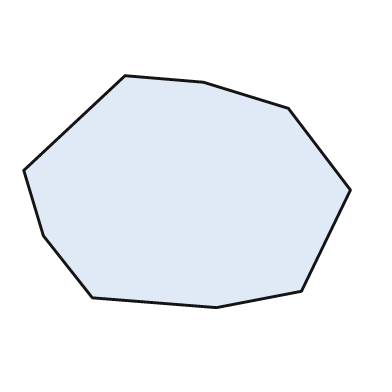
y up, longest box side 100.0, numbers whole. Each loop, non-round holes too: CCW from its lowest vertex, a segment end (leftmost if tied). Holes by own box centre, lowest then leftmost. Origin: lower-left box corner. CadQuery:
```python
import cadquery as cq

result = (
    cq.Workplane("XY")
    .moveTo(59.0, 0.0)
    .lineTo(85.0, 5.0)
    .lineTo(100.0, 36.0)
    .lineTo(81.0, 61.0)
    .lineTo(55.0, 69.0)
    .lineTo(31.0, 71.0)
    .lineTo(0.0, 42.0)
    .lineTo(6.0, 22.0)
    .lineTo(21.0, 3.0)
    .close()
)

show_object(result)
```